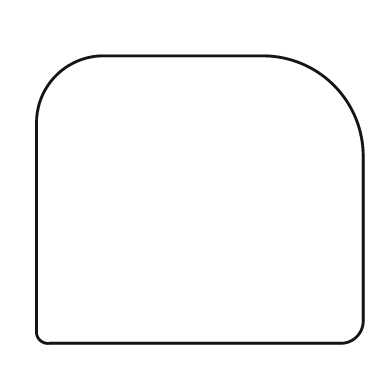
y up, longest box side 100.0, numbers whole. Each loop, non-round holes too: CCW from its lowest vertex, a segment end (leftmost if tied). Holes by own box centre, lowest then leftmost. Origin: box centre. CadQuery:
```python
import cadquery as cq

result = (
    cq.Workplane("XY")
    .moveTo(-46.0, -44.0)
    .lineTo(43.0, -44.0)
    .threePointArc((48.0, -42.0), (50.0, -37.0))
    .lineTo(50.0, 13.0)
    .threePointArc((41.0, 35.0), (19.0, 44.0))
    .lineTo(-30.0, 44.0)
    .threePointArc((-44.0, 38.0), (-50.0, 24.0))
    .lineTo(-50.0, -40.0)
    .threePointArc((-49.0, -43.0), (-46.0, -44.0))
    .close()
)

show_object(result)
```